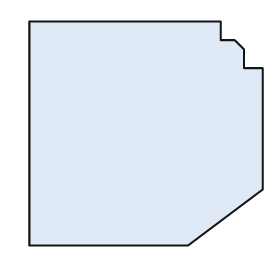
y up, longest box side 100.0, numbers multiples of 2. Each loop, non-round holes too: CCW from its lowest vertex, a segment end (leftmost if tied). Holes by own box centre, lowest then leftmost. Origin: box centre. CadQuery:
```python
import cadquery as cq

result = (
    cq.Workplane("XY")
    .moveTo(-50.0, -48.0)
    .lineTo(18.0, -48.0)
    .lineTo(50.0, -24.0)
    .lineTo(50.0, 28.0)
    .lineTo(42.0, 28.0)
    .lineTo(42.0, 36.0)
    .lineTo(38.0, 40.0)
    .lineTo(32.0, 40.0)
    .lineTo(32.0, 48.0)
    .lineTo(-50.0, 48.0)
    .close()
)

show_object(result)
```